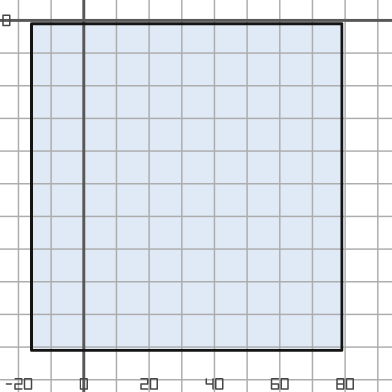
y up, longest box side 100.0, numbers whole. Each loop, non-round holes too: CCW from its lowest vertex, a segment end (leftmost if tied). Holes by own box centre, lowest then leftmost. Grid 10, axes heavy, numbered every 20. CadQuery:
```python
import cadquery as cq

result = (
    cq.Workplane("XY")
    .moveTo(-16.0, -101.0)
    .lineTo(79.0, -101.0)
    .lineTo(79.0, -1.0)
    .lineTo(-16.0, -1.0)
    .close()
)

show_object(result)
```